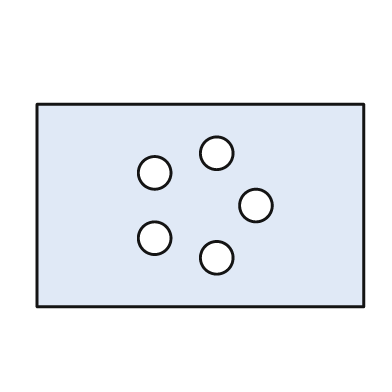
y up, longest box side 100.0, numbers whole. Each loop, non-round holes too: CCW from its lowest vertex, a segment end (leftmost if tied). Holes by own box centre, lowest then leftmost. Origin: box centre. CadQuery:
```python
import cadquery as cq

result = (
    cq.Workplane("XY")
    .moveTo(-50.0, -31.0)
    .lineTo(50.0, -31.0)
    .lineTo(50.0, 31.0)
    .lineTo(-50.0, 31.0)
    .close()
    .moveTo(5.0, -16.0)
    .circle(5.0)
    .moveTo(-14.0, -10.0)
    .circle(5.0)
    .moveTo(17.0, 0.0)
    .circle(5.0)
    .moveTo(-14.0, 10.0)
    .circle(5.0)
    .moveTo(5.0, 16.0)
    .circle(5.0)
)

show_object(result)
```